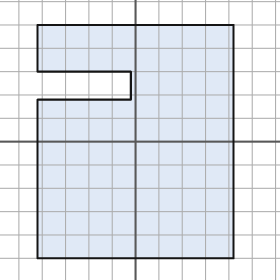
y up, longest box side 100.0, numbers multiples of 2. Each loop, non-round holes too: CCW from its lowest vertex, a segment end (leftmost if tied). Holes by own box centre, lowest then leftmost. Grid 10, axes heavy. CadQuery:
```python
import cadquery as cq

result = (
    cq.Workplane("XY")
    .moveTo(-42.0, -50.0)
    .lineTo(42.0, -50.0)
    .lineTo(42.0, 50.0)
    .lineTo(-42.0, 50.0)
    .lineTo(-42.0, 30.0)
    .lineTo(-2.0, 30.0)
    .lineTo(-2.0, 18.0)
    .lineTo(-42.0, 18.0)
    .close()
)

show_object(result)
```